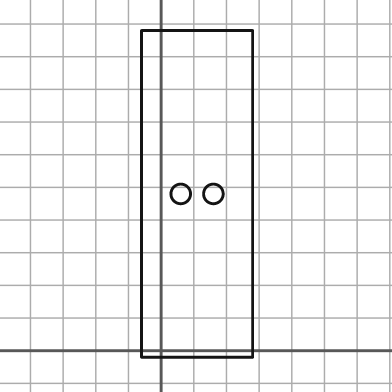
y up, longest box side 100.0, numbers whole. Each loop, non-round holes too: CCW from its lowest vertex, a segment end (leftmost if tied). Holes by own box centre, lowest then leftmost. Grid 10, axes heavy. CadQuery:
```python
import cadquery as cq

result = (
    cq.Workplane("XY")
    .moveTo(-6.0, -2.0)
    .lineTo(28.0, -2.0)
    .lineTo(28.0, 98.0)
    .lineTo(-6.0, 98.0)
    .close()
    .moveTo(6.0, 48.0)
    .circle(3.0)
    .moveTo(16.0, 48.0)
    .circle(3.0)
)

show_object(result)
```